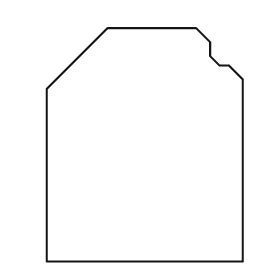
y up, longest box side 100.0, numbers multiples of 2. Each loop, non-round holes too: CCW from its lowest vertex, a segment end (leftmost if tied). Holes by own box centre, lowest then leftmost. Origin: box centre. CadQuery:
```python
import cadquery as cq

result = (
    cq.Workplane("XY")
    .moveTo(-42.0, -50.0)
    .lineTo(42.0, -50.0)
    .lineTo(42.0, 28.0)
    .lineTo(36.0, 34.0)
    .lineTo(32.0, 34.0)
    .lineTo(28.0, 38.0)
    .lineTo(28.0, 44.0)
    .lineTo(22.0, 50.0)
    .lineTo(-16.0, 50.0)
    .lineTo(-42.0, 24.0)
    .close()
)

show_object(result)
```